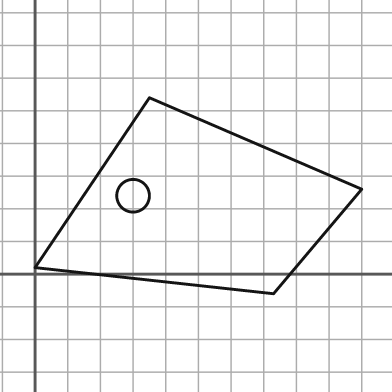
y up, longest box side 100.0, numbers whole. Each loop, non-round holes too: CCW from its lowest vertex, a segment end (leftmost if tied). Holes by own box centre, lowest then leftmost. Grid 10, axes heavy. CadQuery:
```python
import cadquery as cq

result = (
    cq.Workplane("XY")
    .moveTo(73.0, -6.0)
    .lineTo(100.0, 26.0)
    .lineTo(35.0, 54.0)
    .lineTo(0.0, 2.0)
    .close()
    .moveTo(30.0, 24.0)
    .circle(5.0)
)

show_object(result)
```